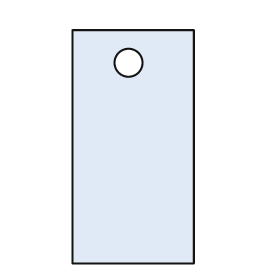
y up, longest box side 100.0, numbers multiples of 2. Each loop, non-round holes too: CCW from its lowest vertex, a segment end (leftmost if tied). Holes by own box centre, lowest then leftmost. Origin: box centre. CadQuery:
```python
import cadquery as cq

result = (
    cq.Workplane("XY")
    .moveTo(-26.0, -50.0)
    .lineTo(26.0, -50.0)
    .lineTo(26.0, 50.0)
    .lineTo(-26.0, 50.0)
    .close()
    .moveTo(-2.0, 36.0)
    .circle(6.0)
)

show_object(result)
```